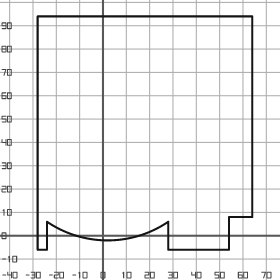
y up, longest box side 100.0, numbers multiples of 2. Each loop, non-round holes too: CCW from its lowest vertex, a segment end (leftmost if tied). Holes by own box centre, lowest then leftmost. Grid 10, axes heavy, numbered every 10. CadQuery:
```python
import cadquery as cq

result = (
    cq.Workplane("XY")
    .moveTo(-28.0, -6.0)
    .lineTo(-24.0, -6.0)
    .lineTo(-24.0, 6.0)
    .threePointArc((2.0, -2.0), (28.0, 6.0))
    .lineTo(28.0, -6.0)
    .lineTo(54.0, -6.0)
    .lineTo(54.0, 8.0)
    .lineTo(64.0, 8.0)
    .lineTo(64.0, 94.0)
    .lineTo(-28.0, 94.0)
    .close()
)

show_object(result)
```